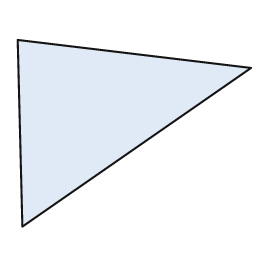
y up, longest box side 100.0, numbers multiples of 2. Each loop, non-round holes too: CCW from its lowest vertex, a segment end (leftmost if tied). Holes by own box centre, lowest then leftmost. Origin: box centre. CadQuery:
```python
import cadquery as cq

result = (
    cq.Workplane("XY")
    .moveTo(-48.0, -40.0)
    .lineTo(50.0, 28.0)
    .lineTo(-50.0, 40.0)
    .close()
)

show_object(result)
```